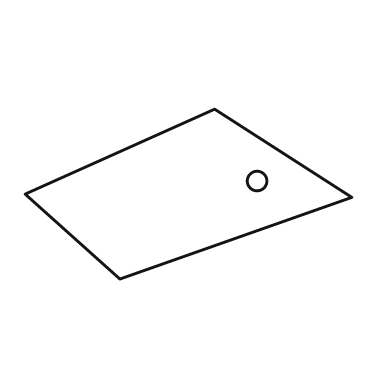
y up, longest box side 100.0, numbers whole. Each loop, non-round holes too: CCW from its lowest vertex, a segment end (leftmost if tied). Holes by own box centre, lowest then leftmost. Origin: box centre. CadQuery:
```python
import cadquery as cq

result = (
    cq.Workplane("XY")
    .moveTo(-21.0, -26.0)
    .lineTo(50.0, -1.0)
    .lineTo(8.0, 26.0)
    .lineTo(-50.0, 0.0)
    .close()
    .moveTo(21.0, 4.0)
    .circle(3.0)
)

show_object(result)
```